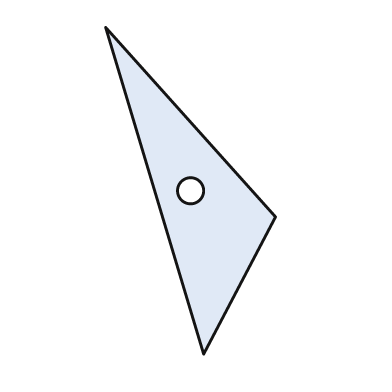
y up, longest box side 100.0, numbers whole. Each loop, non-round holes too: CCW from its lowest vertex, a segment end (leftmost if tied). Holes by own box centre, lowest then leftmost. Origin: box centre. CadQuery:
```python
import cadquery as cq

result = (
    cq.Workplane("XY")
    .moveTo(4.0, -50.0)
    .lineTo(26.0, -8.0)
    .lineTo(-26.0, 50.0)
    .close()
    .moveTo(0.0, 0.0)
    .circle(4.0)
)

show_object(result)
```